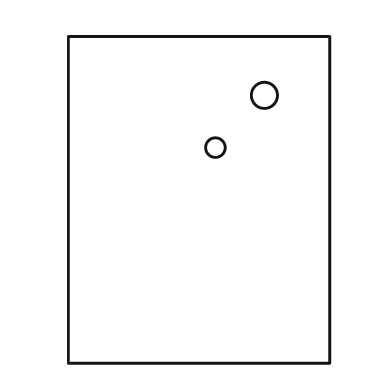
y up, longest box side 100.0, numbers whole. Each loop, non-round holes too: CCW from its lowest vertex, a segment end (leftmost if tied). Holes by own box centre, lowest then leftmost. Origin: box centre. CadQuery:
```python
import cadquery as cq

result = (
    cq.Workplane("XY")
    .moveTo(-40.0, -50.0)
    .lineTo(40.0, -50.0)
    .lineTo(40.0, 50.0)
    .lineTo(-40.0, 50.0)
    .close()
    .moveTo(5.0, 16.0)
    .circle(3.0)
    .moveTo(20.0, 32.0)
    .circle(4.0)
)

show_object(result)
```